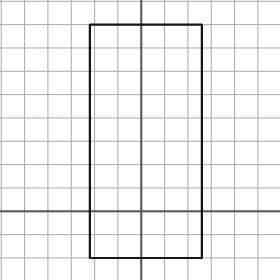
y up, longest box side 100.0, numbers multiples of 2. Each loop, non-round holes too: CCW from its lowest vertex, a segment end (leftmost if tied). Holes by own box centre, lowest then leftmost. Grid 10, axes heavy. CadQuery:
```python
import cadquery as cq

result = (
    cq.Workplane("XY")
    .moveTo(-22.0, -20.0)
    .lineTo(26.0, -20.0)
    .lineTo(26.0, 80.0)
    .lineTo(-22.0, 80.0)
    .close()
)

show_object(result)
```